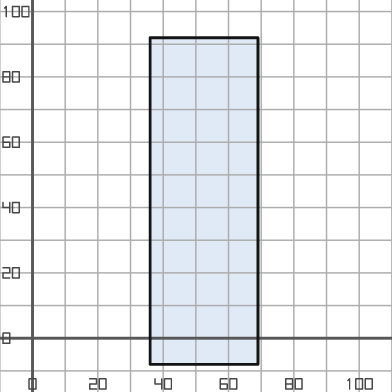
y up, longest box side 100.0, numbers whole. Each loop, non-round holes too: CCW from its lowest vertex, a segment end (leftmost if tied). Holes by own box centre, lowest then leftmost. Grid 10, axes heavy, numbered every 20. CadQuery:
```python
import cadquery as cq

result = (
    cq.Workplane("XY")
    .moveTo(36.0, -8.0)
    .lineTo(69.0, -8.0)
    .lineTo(69.0, 92.0)
    .lineTo(36.0, 92.0)
    .close()
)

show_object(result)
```